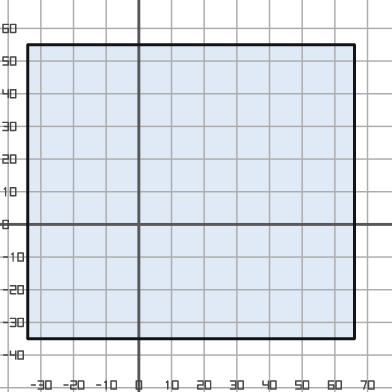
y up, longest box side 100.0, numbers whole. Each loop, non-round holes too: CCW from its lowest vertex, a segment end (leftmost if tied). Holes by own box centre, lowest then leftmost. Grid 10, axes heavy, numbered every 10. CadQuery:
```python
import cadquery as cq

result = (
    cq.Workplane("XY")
    .moveTo(-34.0, -35.0)
    .lineTo(66.0, -35.0)
    .lineTo(66.0, 55.0)
    .lineTo(-34.0, 55.0)
    .close()
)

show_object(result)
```